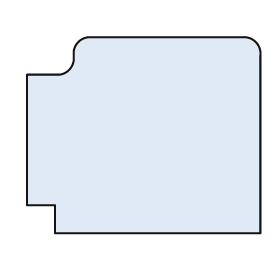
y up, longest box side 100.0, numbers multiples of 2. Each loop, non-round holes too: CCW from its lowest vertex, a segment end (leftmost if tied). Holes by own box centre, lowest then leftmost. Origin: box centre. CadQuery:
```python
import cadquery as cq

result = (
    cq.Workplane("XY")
    .moveTo(-38.0, -42.0)
    .lineTo(50.0, -42.0)
    .lineTo(50.0, 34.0)
    .threePointArc((48.0, 40.0), (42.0, 42.0))
    .lineTo(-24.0, 42.0)
    .threePointArc((-28.0, 40.0), (-30.0, 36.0))
    .lineTo(-30.0, 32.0)
    .threePointArc((-32.0, 28.0), (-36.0, 26.0))
    .lineTo(-50.0, 26.0)
    .lineTo(-50.0, -30.0)
    .lineTo(-38.0, -30.0)
    .close()
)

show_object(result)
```